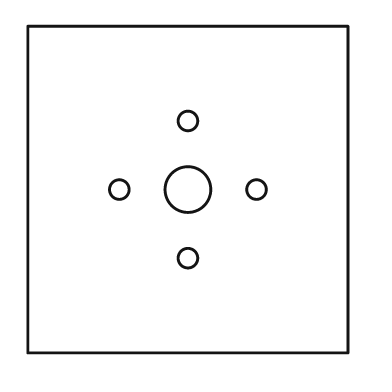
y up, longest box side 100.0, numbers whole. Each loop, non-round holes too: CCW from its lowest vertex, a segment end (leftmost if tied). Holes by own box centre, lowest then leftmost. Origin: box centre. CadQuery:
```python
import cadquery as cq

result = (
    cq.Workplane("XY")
    .moveTo(-49.0, -50.0)
    .lineTo(49.0, -50.0)
    .lineTo(49.0, 50.0)
    .lineTo(-49.0, 50.0)
    .close()
    .moveTo(0.0, -21.0)
    .circle(3.0)
    .moveTo(-21.0, 0.0)
    .circle(3.0)
    .moveTo(0.0, 0.0)
    .circle(7.0)
    .moveTo(21.0, 0.0)
    .circle(3.0)
    .moveTo(0.0, 21.0)
    .circle(3.0)
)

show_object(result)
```